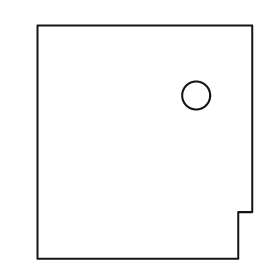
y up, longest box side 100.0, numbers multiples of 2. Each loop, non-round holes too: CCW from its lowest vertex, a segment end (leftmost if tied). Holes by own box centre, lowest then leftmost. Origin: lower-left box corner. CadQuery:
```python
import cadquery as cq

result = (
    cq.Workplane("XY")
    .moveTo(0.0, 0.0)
    .lineTo(86.0, 0.0)
    .lineTo(86.0, 20.0)
    .lineTo(92.0, 20.0)
    .lineTo(92.0, 100.0)
    .lineTo(0.0, 100.0)
    .close()
    .moveTo(68.0, 70.0)
    .circle(6.0)
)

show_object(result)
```